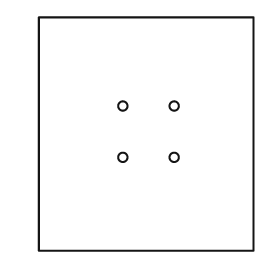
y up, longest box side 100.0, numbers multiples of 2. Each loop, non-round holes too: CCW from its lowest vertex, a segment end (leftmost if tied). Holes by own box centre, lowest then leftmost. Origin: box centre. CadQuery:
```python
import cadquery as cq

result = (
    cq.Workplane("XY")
    .moveTo(-46.0, -50.0)
    .lineTo(46.0, -50.0)
    .lineTo(46.0, 50.0)
    .lineTo(-46.0, 50.0)
    .close()
    .moveTo(-10.0, -10.0)
    .circle(2.0)
    .moveTo(12.0, -10.0)
    .circle(2.0)
    .moveTo(-10.0, 12.0)
    .circle(2.0)
    .moveTo(12.0, 12.0)
    .circle(2.0)
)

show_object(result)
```